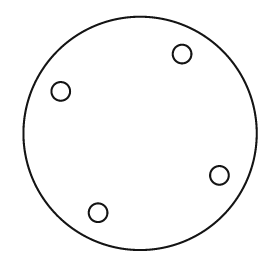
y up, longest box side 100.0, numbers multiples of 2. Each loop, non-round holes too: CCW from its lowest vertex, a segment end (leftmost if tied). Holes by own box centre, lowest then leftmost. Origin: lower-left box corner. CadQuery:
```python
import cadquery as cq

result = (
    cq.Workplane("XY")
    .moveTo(50.0, 50.0)
    .circle(50.0)
    .moveTo(32.0, 16.0)
    .circle(4.0)
    .moveTo(84.0, 32.0)
    .circle(4.0)
    .moveTo(16.0, 68.0)
    .circle(4.0)
    .moveTo(68.0, 84.0)
    .circle(4.0)
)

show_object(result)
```